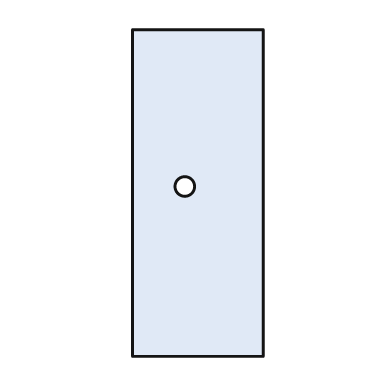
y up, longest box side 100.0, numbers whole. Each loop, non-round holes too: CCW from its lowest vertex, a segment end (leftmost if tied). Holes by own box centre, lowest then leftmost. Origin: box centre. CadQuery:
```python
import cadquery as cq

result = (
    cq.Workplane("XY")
    .moveTo(-20.0, -50.0)
    .lineTo(20.0, -50.0)
    .lineTo(20.0, 50.0)
    .lineTo(-20.0, 50.0)
    .close()
    .moveTo(-4.0, 2.0)
    .circle(3.0)
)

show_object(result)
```